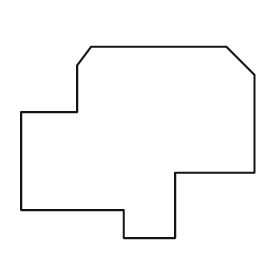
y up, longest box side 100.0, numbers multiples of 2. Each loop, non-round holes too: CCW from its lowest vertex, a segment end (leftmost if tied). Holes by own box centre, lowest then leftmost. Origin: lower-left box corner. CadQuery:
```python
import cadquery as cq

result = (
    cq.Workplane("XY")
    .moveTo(44.0, 0.0)
    .lineTo(66.0, 0.0)
    .lineTo(66.0, 28.0)
    .lineTo(100.0, 28.0)
    .lineTo(100.0, 70.0)
    .lineTo(88.0, 82.0)
    .lineTo(30.0, 82.0)
    .lineTo(24.0, 74.0)
    .lineTo(24.0, 54.0)
    .lineTo(0.0, 54.0)
    .lineTo(0.0, 12.0)
    .lineTo(44.0, 12.0)
    .close()
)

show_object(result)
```